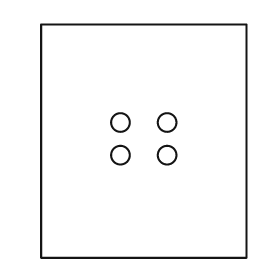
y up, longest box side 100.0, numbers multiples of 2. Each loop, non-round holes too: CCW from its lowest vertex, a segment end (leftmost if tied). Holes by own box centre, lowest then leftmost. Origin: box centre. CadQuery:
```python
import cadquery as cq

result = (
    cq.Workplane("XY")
    .moveTo(-44.0, -50.0)
    .lineTo(44.0, -50.0)
    .lineTo(44.0, 50.0)
    .lineTo(-44.0, 50.0)
    .close()
    .moveTo(-10.0, -6.0)
    .circle(4.0)
    .moveTo(10.0, -6.0)
    .circle(4.0)
    .moveTo(-10.0, 8.0)
    .circle(4.0)
    .moveTo(10.0, 8.0)
    .circle(4.0)
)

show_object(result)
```